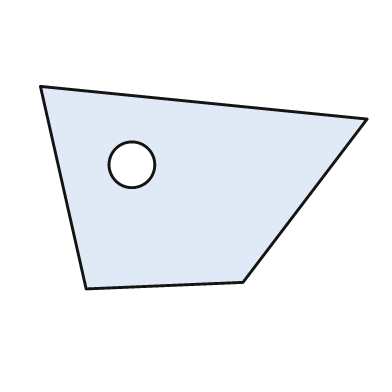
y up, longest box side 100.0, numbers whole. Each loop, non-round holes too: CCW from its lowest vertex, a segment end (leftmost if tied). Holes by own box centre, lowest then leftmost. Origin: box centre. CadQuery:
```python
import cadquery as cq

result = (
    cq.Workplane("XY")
    .moveTo(-36.0, -31.0)
    .lineTo(12.0, -29.0)
    .lineTo(50.0, 21.0)
    .lineTo(-50.0, 31.0)
    .close()
    .moveTo(-22.0, 7.0)
    .circle(7.0)
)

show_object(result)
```